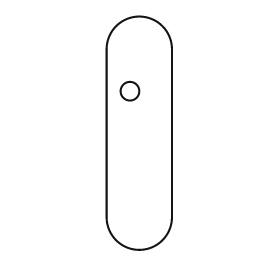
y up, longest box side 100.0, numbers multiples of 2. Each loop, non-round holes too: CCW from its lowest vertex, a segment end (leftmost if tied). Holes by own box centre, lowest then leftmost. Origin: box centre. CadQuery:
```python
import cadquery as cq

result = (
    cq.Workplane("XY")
    .moveTo(-14.0, -36.0)
    .threePointArc((0.0, -50.0), (14.0, -36.0))
    .lineTo(14.0, 36.0)
    .threePointArc((0.0, 50.0), (-14.0, 36.0))
    .close()
    .moveTo(-4.0, 18.0)
    .circle(4.0)
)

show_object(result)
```